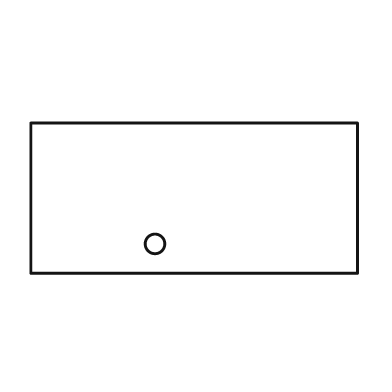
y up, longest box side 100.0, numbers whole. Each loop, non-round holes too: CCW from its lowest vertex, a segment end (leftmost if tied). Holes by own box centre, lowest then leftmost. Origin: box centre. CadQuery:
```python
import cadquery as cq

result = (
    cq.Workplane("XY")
    .moveTo(-50.0, -23.0)
    .lineTo(50.0, -23.0)
    .lineTo(50.0, 23.0)
    .lineTo(-50.0, 23.0)
    .close()
    .moveTo(-12.0, -14.0)
    .circle(3.0)
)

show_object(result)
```